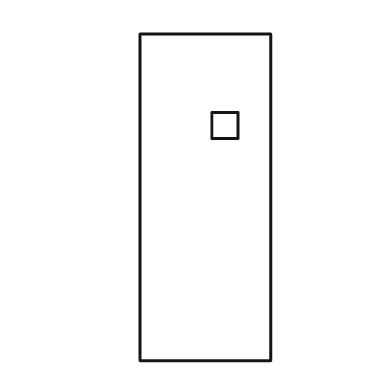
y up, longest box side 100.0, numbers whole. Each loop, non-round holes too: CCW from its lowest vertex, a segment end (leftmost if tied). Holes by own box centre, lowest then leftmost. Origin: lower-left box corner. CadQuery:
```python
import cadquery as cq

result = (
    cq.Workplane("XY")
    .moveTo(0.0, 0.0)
    .lineTo(40.0, 0.0)
    .lineTo(40.0, 100.0)
    .lineTo(0.0, 100.0)
    .close()
    .moveTo(22.0, 68.0)
    .lineTo(30.0, 68.0)
    .lineTo(30.0, 76.0)
    .lineTo(22.0, 76.0)
    .close()
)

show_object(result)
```